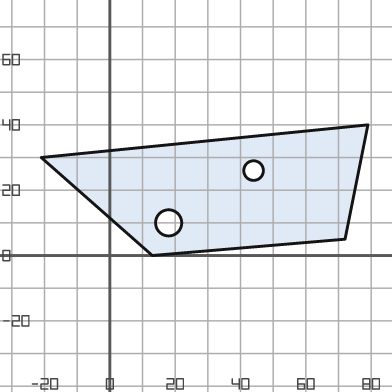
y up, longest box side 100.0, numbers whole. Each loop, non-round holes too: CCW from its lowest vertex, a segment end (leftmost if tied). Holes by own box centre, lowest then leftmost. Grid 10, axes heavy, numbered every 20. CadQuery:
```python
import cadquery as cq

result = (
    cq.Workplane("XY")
    .moveTo(13.0, 0.0)
    .lineTo(72.0, 5.0)
    .lineTo(79.0, 40.0)
    .lineTo(-21.0, 30.0)
    .close()
    .moveTo(18.0, 10.0)
    .circle(4.0)
    .moveTo(44.0, 26.0)
    .circle(3.0)
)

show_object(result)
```